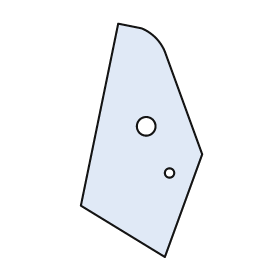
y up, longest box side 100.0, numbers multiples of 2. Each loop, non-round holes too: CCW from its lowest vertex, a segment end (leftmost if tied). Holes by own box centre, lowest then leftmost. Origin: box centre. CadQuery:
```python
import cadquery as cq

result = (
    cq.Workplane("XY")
    .moveTo(10.0, -50.0)
    .lineTo(26.0, -6.0)
    .lineTo(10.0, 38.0)
    .threePointArc((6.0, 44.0), (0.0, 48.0))
    .lineTo(-10.0, 50.0)
    .lineTo(-26.0, -28.0)
    .close()
    .moveTo(12.0, -14.0)
    .circle(2.0)
    .moveTo(2.0, 6.0)
    .circle(4.0)
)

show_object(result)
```